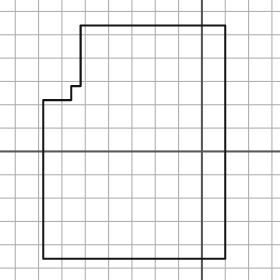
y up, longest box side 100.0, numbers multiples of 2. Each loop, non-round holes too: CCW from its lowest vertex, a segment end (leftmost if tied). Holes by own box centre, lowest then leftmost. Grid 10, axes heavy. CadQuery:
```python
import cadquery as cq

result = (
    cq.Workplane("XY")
    .moveTo(-68.0, -46.0)
    .lineTo(10.0, -46.0)
    .lineTo(10.0, 54.0)
    .lineTo(-52.0, 54.0)
    .lineTo(-52.0, 28.0)
    .lineTo(-56.0, 28.0)
    .lineTo(-56.0, 22.0)
    .lineTo(-68.0, 22.0)
    .close()
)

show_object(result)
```